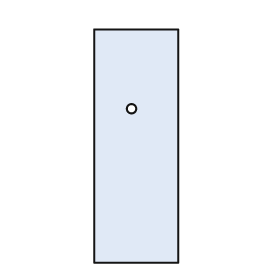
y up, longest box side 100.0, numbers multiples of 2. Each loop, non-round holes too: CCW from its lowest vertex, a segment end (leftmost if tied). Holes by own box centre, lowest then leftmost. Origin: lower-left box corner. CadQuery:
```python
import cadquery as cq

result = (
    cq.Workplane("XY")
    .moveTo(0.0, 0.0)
    .lineTo(36.0, 0.0)
    .lineTo(36.0, 100.0)
    .lineTo(0.0, 100.0)
    .close()
    .moveTo(16.0, 66.0)
    .circle(2.0)
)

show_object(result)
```